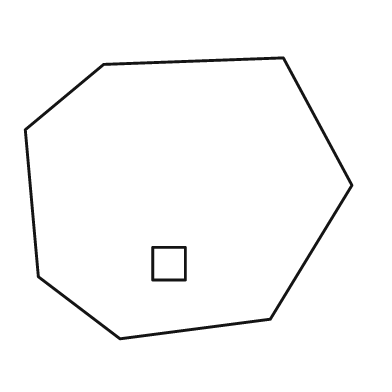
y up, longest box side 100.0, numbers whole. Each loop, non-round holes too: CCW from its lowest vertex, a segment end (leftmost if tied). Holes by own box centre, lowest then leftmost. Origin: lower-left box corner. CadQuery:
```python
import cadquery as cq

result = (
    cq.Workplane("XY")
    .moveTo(29.0, 0.0)
    .lineTo(75.0, 6.0)
    .lineTo(100.0, 47.0)
    .lineTo(79.0, 86.0)
    .lineTo(24.0, 84.0)
    .lineTo(0.0, 64.0)
    .lineTo(4.0, 19.0)
    .close()
    .moveTo(39.0, 18.0)
    .lineTo(49.0, 18.0)
    .lineTo(49.0, 28.0)
    .lineTo(39.0, 28.0)
    .close()
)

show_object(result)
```